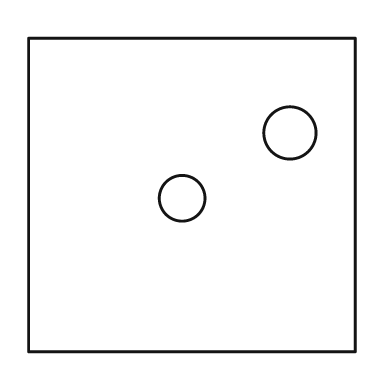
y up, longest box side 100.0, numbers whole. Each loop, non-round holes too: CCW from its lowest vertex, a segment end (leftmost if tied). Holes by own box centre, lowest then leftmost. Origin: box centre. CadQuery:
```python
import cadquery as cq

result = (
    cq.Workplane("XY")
    .moveTo(-50.0, -48.0)
    .lineTo(50.0, -48.0)
    .lineTo(50.0, 48.0)
    .lineTo(-50.0, 48.0)
    .close()
    .moveTo(-3.0, -1.0)
    .circle(7.0)
    .moveTo(30.0, 19.0)
    .circle(8.0)
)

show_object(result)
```